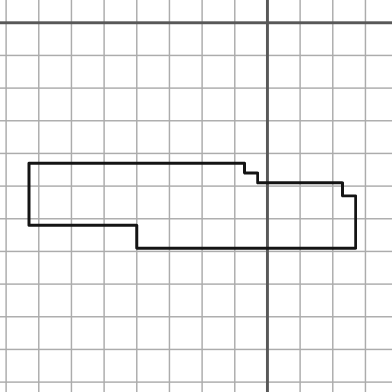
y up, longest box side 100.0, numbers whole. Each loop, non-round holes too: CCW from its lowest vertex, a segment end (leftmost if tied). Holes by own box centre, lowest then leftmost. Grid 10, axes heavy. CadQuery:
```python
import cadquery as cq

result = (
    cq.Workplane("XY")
    .moveTo(-40.0, -69.0)
    .lineTo(27.0, -69.0)
    .lineTo(27.0, -53.0)
    .lineTo(23.0, -53.0)
    .lineTo(23.0, -49.0)
    .lineTo(-3.0, -49.0)
    .lineTo(-3.0, -46.0)
    .lineTo(-7.0, -46.0)
    .lineTo(-7.0, -43.0)
    .lineTo(-73.0, -43.0)
    .lineTo(-73.0, -62.0)
    .lineTo(-40.0, -62.0)
    .close()
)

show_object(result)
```